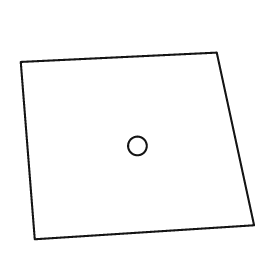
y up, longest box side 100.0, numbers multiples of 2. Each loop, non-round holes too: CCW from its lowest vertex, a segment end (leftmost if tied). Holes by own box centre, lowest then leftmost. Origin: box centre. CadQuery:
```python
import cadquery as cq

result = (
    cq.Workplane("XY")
    .moveTo(-44.0, -40.0)
    .lineTo(50.0, -34.0)
    .lineTo(34.0, 40.0)
    .lineTo(-50.0, 36.0)
    .close()
    .moveTo(0.0, 0.0)
    .circle(4.0)
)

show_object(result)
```